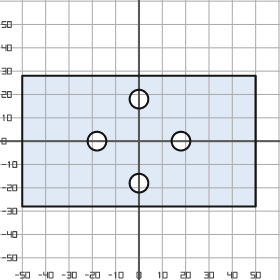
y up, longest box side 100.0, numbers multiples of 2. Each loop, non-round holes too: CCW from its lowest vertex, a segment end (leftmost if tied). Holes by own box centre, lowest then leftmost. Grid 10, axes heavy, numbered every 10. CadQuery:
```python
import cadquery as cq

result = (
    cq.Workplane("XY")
    .moveTo(-50.0, -28.0)
    .lineTo(50.0, -28.0)
    .lineTo(50.0, 28.0)
    .lineTo(-50.0, 28.0)
    .close()
    .moveTo(0.0, -18.0)
    .circle(4.0)
    .moveTo(-18.0, 0.0)
    .circle(4.0)
    .moveTo(18.0, 0.0)
    .circle(4.0)
    .moveTo(0.0, 18.0)
    .circle(4.0)
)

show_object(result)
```